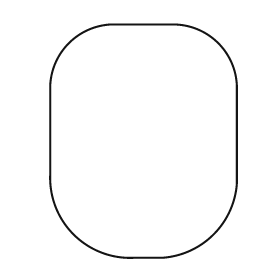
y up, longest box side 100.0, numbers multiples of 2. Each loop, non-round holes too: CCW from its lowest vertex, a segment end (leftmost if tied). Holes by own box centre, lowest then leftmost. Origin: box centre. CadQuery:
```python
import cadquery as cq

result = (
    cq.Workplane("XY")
    .moveTo(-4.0, -50.0)
    .lineTo(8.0, -50.0)
    .threePointArc((30.0, -40.0), (40.0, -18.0))
    .lineTo(40.0, 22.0)
    .threePointArc((32.0, 42.0), (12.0, 50.0))
    .lineTo(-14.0, 50.0)
    .threePointArc((-32.0, 42.0), (-40.0, 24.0))
    .lineTo(-40.0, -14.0)
    .threePointArc((-30.0, -40.0), (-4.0, -50.0))
    .close()
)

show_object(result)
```